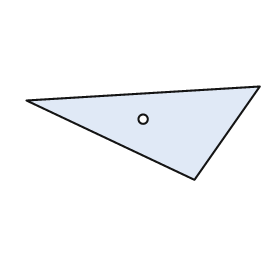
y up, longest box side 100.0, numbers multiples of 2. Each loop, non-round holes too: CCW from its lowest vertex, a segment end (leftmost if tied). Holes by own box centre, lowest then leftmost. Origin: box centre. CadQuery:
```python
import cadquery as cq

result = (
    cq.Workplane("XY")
    .moveTo(22.0, -20.0)
    .lineTo(50.0, 20.0)
    .lineTo(-50.0, 14.0)
    .close()
    .moveTo(0.0, 6.0)
    .circle(2.0)
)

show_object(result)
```